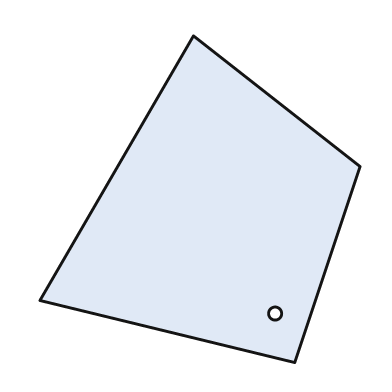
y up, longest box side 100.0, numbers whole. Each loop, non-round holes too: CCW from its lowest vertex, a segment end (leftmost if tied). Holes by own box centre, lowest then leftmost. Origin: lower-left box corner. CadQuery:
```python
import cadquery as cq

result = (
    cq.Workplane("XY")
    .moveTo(78.0, 0.0)
    .lineTo(98.0, 60.0)
    .lineTo(47.0, 100.0)
    .lineTo(0.0, 19.0)
    .close()
    .moveTo(72.0, 15.0)
    .circle(2.0)
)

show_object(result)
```